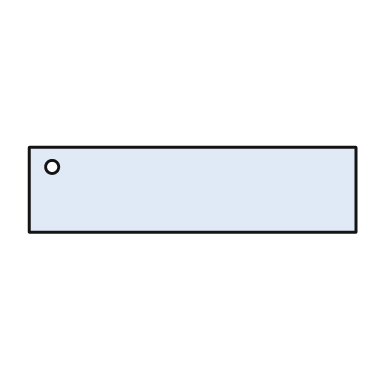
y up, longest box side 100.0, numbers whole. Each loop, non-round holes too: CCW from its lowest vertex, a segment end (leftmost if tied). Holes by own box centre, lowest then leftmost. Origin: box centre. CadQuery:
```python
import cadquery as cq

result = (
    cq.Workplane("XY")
    .moveTo(-50.0, -13.0)
    .lineTo(50.0, -13.0)
    .lineTo(50.0, 13.0)
    .lineTo(-50.0, 13.0)
    .close()
    .moveTo(-43.0, 7.0)
    .circle(2.0)
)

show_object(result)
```